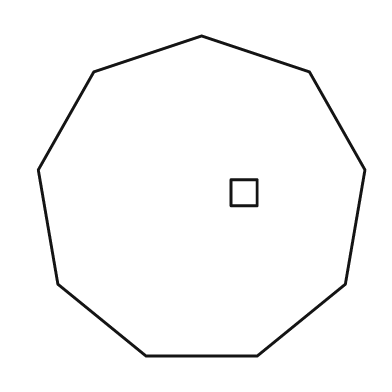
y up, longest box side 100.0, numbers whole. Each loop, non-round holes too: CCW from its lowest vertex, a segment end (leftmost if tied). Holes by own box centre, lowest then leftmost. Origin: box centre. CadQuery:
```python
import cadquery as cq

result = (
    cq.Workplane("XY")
    .moveTo(-17.0, -49.0)
    .lineTo(17.0, -49.0)
    .lineTo(44.0, -27.0)
    .lineTo(50.0, 8.0)
    .lineTo(33.0, 38.0)
    .lineTo(0.0, 49.0)
    .lineTo(-33.0, 38.0)
    .lineTo(-50.0, 8.0)
    .lineTo(-44.0, -27.0)
    .close()
    .moveTo(9.0, -3.0)
    .lineTo(17.0, -3.0)
    .lineTo(17.0, 5.0)
    .lineTo(9.0, 5.0)
    .close()
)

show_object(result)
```